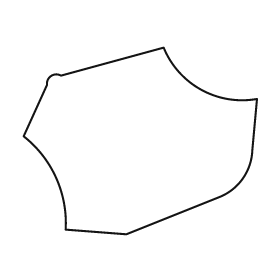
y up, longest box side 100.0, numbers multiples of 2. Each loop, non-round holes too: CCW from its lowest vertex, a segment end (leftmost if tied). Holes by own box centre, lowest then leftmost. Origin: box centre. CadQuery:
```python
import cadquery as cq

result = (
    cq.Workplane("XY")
    .moveTo(-6.0, -40.0)
    .lineTo(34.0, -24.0)
    .threePointArc((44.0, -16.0), (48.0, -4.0))
    .lineTo(50.0, 18.0)
    .threePointArc((26.0, 22.0), (10.0, 40.0))
    .lineTo(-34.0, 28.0)
    .threePointArc((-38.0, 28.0), (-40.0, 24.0))
    .lineTo(-50.0, 2.0)
    .threePointArc((-36.0, -16.0), (-32.0, -38.0))
    .close()
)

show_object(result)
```